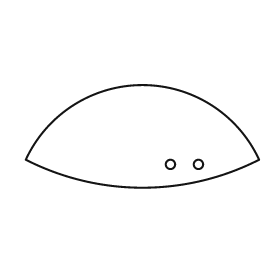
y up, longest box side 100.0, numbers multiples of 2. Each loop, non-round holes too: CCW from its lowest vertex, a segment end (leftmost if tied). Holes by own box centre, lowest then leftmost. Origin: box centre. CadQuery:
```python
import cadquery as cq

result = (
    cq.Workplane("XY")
    .moveTo(-50.0, -10.0)
    .threePointArc((0.0, -22.0), (50.0, -10.0))
    .threePointArc((0.0, 22.0), (-50.0, -10.0))
    .close()
    .moveTo(12.0, -12.0)
    .circle(2.0)
    .moveTo(24.0, -12.0)
    .circle(2.0)
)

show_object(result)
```